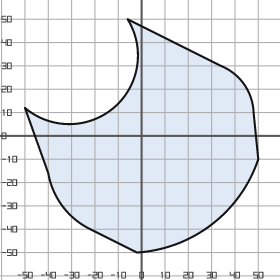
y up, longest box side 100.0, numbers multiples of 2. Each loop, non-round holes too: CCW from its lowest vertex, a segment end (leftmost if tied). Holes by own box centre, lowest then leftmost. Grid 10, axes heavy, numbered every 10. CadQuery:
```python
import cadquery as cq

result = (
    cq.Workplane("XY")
    .moveTo(-2.0, -50.0)
    .threePointArc((30.0, -38.0), (50.0, -10.0))
    .lineTo(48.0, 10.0)
    .threePointArc((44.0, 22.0), (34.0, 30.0))
    .lineTo(-6.0, 50.0)
    .threePointArc((-12.0, 12.0), (-50.0, 12.0))
    .lineTo(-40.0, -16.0)
    .threePointArc((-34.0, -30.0), (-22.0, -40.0))
    .close()
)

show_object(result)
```